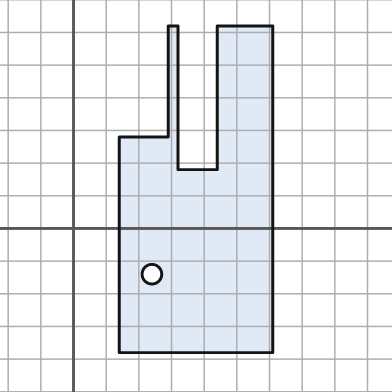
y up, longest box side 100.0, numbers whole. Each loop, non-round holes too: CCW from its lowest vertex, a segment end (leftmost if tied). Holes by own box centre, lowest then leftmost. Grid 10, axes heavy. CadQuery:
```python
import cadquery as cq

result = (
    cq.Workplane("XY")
    .moveTo(14.0, -38.0)
    .lineTo(61.0, -38.0)
    .lineTo(61.0, 62.0)
    .lineTo(44.0, 62.0)
    .lineTo(44.0, 18.0)
    .lineTo(32.0, 18.0)
    .lineTo(32.0, 62.0)
    .lineTo(29.0, 62.0)
    .lineTo(29.0, 28.0)
    .lineTo(14.0, 28.0)
    .close()
    .moveTo(24.0, -14.0)
    .circle(3.0)
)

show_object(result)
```